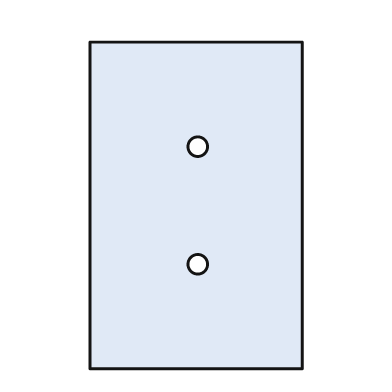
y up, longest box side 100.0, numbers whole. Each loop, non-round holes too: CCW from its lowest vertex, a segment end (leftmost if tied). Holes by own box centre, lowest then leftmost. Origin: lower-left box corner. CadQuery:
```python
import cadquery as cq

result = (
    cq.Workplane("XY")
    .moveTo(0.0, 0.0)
    .lineTo(65.0, 0.0)
    .lineTo(65.0, 100.0)
    .lineTo(0.0, 100.0)
    .close()
    .moveTo(33.0, 32.0)
    .circle(3.0)
    .moveTo(33.0, 68.0)
    .circle(3.0)
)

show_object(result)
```